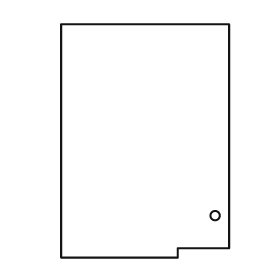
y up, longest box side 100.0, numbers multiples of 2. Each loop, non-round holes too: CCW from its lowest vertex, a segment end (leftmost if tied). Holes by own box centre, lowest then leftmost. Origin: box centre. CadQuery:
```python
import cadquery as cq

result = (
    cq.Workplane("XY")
    .moveTo(-36.0, -50.0)
    .lineTo(14.0, -50.0)
    .lineTo(14.0, -46.0)
    .lineTo(36.0, -46.0)
    .lineTo(36.0, 50.0)
    .lineTo(-36.0, 50.0)
    .close()
    .moveTo(30.0, -32.0)
    .circle(2.0)
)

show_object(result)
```